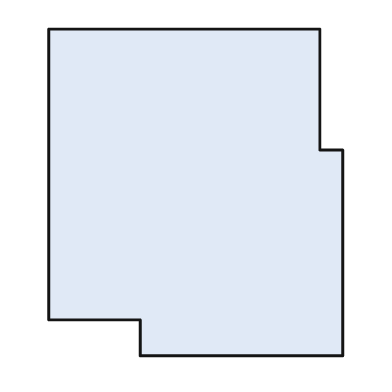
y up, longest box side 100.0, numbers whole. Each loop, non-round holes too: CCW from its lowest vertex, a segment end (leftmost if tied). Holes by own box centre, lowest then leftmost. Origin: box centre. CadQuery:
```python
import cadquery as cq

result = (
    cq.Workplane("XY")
    .moveTo(-17.0, -50.0)
    .lineTo(45.0, -50.0)
    .lineTo(45.0, 13.0)
    .lineTo(38.0, 13.0)
    .lineTo(38.0, 50.0)
    .lineTo(-45.0, 50.0)
    .lineTo(-45.0, -39.0)
    .lineTo(-17.0, -39.0)
    .close()
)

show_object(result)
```